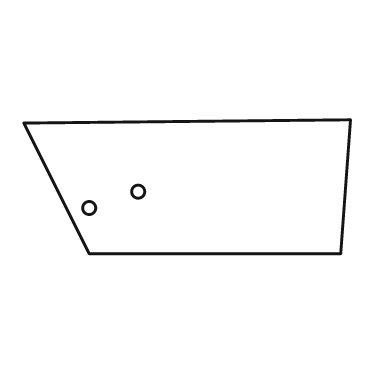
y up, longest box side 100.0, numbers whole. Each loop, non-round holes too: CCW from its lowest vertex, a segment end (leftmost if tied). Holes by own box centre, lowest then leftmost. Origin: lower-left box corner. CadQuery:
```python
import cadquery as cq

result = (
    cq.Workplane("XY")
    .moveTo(20.0, 0.0)
    .lineTo(97.0, 0.0)
    .lineTo(100.0, 41.0)
    .lineTo(0.0, 40.0)
    .close()
    .moveTo(20.0, 14.0)
    .circle(2.0)
    .moveTo(35.0, 19.0)
    .circle(2.0)
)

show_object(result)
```